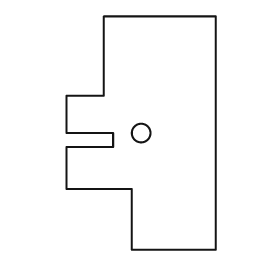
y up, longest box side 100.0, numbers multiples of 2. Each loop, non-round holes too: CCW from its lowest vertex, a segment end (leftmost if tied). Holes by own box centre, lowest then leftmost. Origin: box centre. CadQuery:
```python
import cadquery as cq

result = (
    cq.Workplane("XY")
    .moveTo(-4.0, -50.0)
    .lineTo(32.0, -50.0)
    .lineTo(32.0, 50.0)
    .lineTo(-16.0, 50.0)
    .lineTo(-16.0, 16.0)
    .lineTo(-32.0, 16.0)
    .lineTo(-32.0, 0.0)
    .lineTo(-12.0, 0.0)
    .lineTo(-12.0, -6.0)
    .lineTo(-32.0, -6.0)
    .lineTo(-32.0, -24.0)
    .lineTo(-4.0, -24.0)
    .close()
    .moveTo(0.0, 0.0)
    .circle(4.0)
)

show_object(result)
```